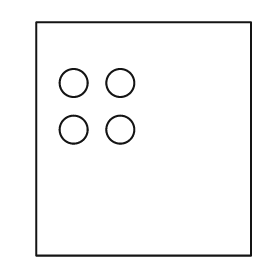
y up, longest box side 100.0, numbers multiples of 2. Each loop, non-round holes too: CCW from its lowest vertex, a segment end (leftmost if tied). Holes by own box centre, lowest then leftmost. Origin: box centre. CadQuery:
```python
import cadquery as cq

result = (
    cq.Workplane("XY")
    .moveTo(-46.0, -50.0)
    .lineTo(46.0, -50.0)
    .lineTo(46.0, 50.0)
    .lineTo(-46.0, 50.0)
    .close()
    .moveTo(-30.0, 4.0)
    .circle(6.0)
    .moveTo(-10.0, 4.0)
    .circle(6.0)
    .moveTo(-30.0, 24.0)
    .circle(6.0)
    .moveTo(-10.0, 24.0)
    .circle(6.0)
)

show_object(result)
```